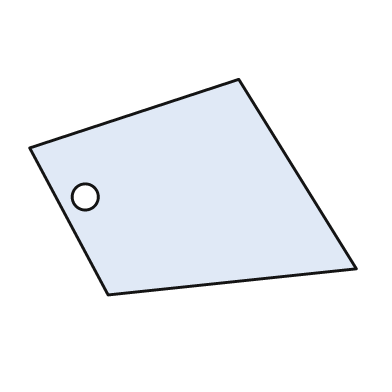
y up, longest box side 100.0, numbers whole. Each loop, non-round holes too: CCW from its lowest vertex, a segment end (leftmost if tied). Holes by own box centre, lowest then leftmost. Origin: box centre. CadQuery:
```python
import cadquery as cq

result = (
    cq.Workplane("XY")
    .moveTo(-26.0, -33.0)
    .lineTo(50.0, -25.0)
    .lineTo(14.0, 33.0)
    .lineTo(-50.0, 12.0)
    .close()
    .moveTo(-33.0, -3.0)
    .circle(4.0)
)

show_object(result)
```